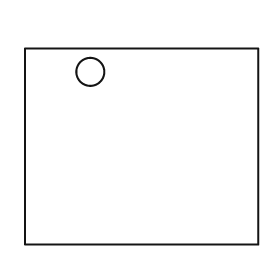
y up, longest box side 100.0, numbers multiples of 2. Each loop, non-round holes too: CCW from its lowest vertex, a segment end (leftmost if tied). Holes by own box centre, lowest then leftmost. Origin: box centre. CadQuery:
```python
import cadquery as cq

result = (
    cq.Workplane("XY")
    .moveTo(-50.0, -42.0)
    .lineTo(50.0, -42.0)
    .lineTo(50.0, 42.0)
    .lineTo(-50.0, 42.0)
    .close()
    .moveTo(-22.0, 32.0)
    .circle(6.0)
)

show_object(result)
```